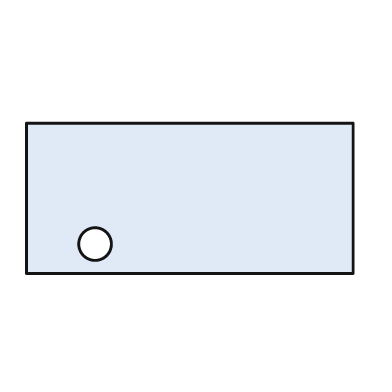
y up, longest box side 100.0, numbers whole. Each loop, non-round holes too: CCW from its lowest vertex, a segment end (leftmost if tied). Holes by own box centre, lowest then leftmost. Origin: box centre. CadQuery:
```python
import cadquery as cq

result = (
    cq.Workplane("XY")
    .moveTo(-50.0, -23.0)
    .lineTo(50.0, -23.0)
    .lineTo(50.0, 23.0)
    .lineTo(-50.0, 23.0)
    .close()
    .moveTo(-29.0, -14.0)
    .circle(5.0)
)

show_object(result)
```